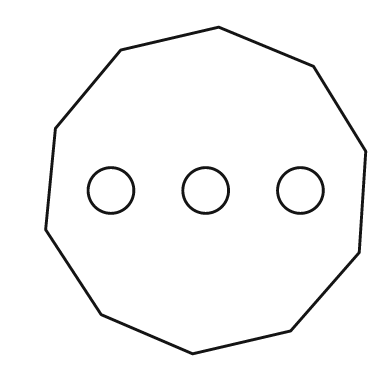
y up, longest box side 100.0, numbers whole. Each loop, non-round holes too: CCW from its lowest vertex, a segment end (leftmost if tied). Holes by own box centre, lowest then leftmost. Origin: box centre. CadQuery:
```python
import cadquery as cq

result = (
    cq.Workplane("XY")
    .moveTo(-4.0, -50.0)
    .lineTo(26.0, -43.0)
    .lineTo(47.0, -19.0)
    .lineTo(49.0, 12.0)
    .lineTo(33.0, 38.0)
    .lineTo(4.0, 50.0)
    .lineTo(-26.0, 43.0)
    .lineTo(-46.0, 19.0)
    .lineTo(-49.0, -12.0)
    .lineTo(-32.0, -38.0)
    .close()
    .moveTo(-29.0, 0.0)
    .circle(7.0)
    .moveTo(0.0, 0.0)
    .circle(7.0)
    .moveTo(29.0, 0.0)
    .circle(7.0)
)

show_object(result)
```